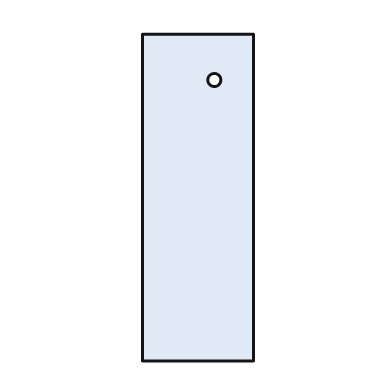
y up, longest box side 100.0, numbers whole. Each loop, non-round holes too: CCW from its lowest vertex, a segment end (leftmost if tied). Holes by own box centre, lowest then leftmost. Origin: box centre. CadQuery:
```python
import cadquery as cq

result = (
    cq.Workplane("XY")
    .moveTo(-17.0, -50.0)
    .lineTo(17.0, -50.0)
    .lineTo(17.0, 50.0)
    .lineTo(-17.0, 50.0)
    .close()
    .moveTo(5.0, 36.0)
    .circle(2.0)
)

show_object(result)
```